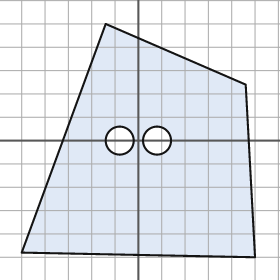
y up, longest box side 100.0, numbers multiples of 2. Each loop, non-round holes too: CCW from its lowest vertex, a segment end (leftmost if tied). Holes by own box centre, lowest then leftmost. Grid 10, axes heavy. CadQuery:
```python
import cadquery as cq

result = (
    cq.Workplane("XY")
    .moveTo(50.0, -50.0)
    .lineTo(46.0, 24.0)
    .lineTo(-14.0, 50.0)
    .lineTo(-50.0, -48.0)
    .close()
    .moveTo(-8.0, 0.0)
    .circle(6.0)
    .moveTo(8.0, 0.0)
    .circle(6.0)
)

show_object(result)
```